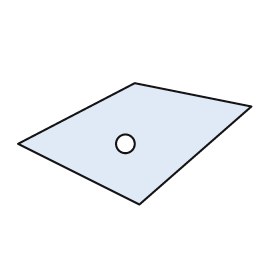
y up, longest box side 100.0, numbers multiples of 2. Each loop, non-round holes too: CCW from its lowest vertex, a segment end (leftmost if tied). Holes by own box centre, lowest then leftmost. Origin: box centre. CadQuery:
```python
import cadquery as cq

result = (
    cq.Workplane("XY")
    .moveTo(2.0, -26.0)
    .lineTo(50.0, 16.0)
    .lineTo(0.0, 26.0)
    .lineTo(-50.0, 0.0)
    .close()
    .moveTo(-4.0, 0.0)
    .circle(4.0)
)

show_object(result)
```